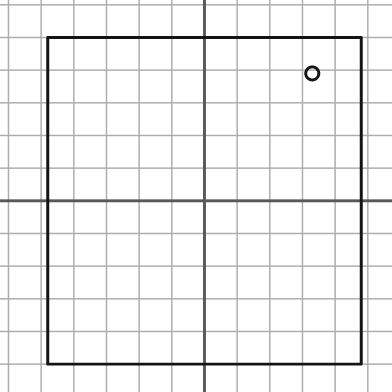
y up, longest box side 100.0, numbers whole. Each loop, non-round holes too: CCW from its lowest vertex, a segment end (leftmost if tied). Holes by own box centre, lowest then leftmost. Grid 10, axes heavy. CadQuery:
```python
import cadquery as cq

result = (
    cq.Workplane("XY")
    .moveTo(-48.0, -50.0)
    .lineTo(48.0, -50.0)
    .lineTo(48.0, 50.0)
    .lineTo(-48.0, 50.0)
    .close()
    .moveTo(33.0, 39.0)
    .circle(2.0)
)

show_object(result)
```